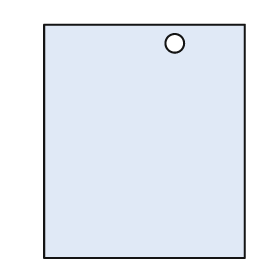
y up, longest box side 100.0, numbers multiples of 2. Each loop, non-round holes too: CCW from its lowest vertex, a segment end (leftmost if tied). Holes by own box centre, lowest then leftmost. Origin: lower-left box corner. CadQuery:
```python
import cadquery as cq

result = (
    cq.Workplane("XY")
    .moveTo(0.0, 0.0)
    .lineTo(86.0, 0.0)
    .lineTo(86.0, 100.0)
    .lineTo(0.0, 100.0)
    .close()
    .moveTo(56.0, 92.0)
    .circle(4.0)
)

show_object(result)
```